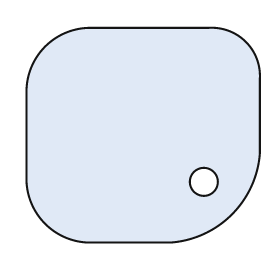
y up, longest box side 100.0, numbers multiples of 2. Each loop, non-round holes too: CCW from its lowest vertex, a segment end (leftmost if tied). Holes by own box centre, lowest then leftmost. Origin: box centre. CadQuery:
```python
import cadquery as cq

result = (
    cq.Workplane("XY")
    .moveTo(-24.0, -46.0)
    .lineTo(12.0, -46.0)
    .threePointArc((38.0, -34.0), (50.0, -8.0))
    .lineTo(50.0, 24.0)
    .threePointArc((44.0, 40.0), (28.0, 46.0))
    .lineTo(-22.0, 46.0)
    .threePointArc((-42.0, 38.0), (-50.0, 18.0))
    .lineTo(-50.0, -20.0)
    .threePointArc((-42.0, -38.0), (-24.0, -46.0))
    .close()
    .moveTo(26.0, -20.0)
    .circle(6.0)
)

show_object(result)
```